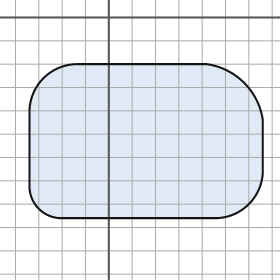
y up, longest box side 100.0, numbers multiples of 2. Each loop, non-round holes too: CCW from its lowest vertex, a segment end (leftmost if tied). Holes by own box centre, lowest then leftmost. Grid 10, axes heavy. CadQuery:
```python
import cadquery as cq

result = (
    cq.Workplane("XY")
    .moveTo(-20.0, -86.0)
    .lineTo(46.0, -86.0)
    .threePointArc((60.0, -80.0), (66.0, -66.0))
    .lineTo(66.0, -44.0)
    .threePointArc((58.0, -28.0), (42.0, -20.0))
    .lineTo(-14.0, -20.0)
    .threePointArc((-28.0, -26.0), (-34.0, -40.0))
    .lineTo(-34.0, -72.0)
    .threePointArc((-30.0, -82.0), (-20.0, -86.0))
    .close()
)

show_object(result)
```